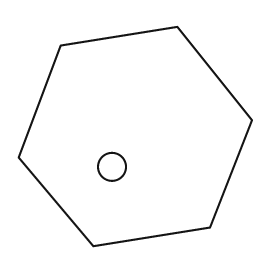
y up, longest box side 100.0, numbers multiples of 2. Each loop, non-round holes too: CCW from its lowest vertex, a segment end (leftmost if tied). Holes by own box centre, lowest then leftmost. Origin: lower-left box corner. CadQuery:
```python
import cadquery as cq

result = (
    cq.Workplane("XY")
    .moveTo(32.0, 0.0)
    .lineTo(82.0, 8.0)
    .lineTo(100.0, 54.0)
    .lineTo(68.0, 94.0)
    .lineTo(18.0, 86.0)
    .lineTo(0.0, 38.0)
    .close()
    .moveTo(40.0, 34.0)
    .circle(6.0)
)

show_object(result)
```